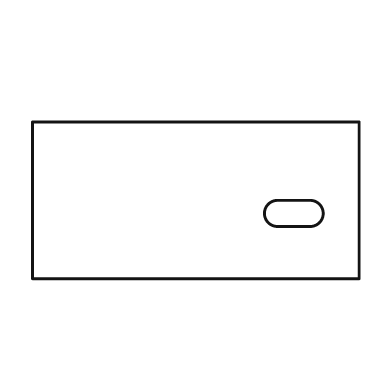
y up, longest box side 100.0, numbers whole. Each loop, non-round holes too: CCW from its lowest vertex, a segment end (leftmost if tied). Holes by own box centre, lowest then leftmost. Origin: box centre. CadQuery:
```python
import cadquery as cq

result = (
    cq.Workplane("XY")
    .moveTo(-50.0, -24.0)
    .lineTo(50.0, -24.0)
    .lineTo(50.0, 24.0)
    .lineTo(-50.0, 24.0)
    .close()
    .moveTo(25.0, -8.0)
    .lineTo(35.0, -8.0)
    .threePointArc((39.0, -4.0), (35.0, 0.0))
    .lineTo(25.0, 0.0)
    .threePointArc((21.0, -4.0), (25.0, -8.0))
    .close()
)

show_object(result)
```